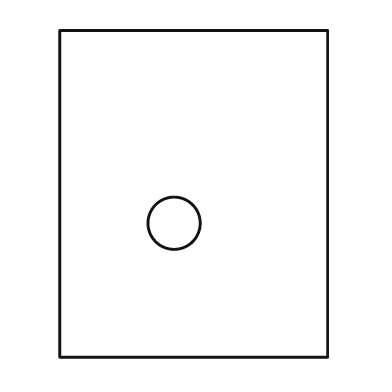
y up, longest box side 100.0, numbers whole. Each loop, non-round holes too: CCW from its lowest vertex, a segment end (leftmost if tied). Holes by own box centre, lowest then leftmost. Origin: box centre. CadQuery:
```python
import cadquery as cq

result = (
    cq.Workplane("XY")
    .moveTo(-41.0, -50.0)
    .lineTo(41.0, -50.0)
    .lineTo(41.0, 50.0)
    .lineTo(-41.0, 50.0)
    .close()
    .moveTo(-6.0, -9.0)
    .circle(8.0)
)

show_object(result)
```